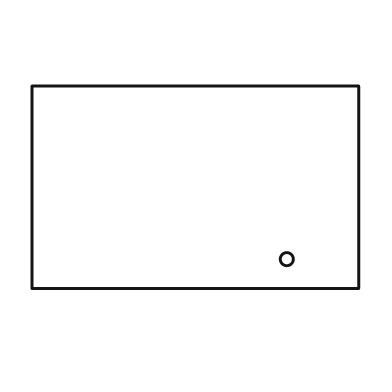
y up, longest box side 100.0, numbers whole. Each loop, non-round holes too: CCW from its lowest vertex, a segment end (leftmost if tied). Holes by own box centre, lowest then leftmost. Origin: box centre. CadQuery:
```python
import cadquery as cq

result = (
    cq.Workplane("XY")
    .moveTo(-50.0, -31.0)
    .lineTo(50.0, -31.0)
    .lineTo(50.0, 31.0)
    .lineTo(-50.0, 31.0)
    .close()
    .moveTo(28.0, -22.0)
    .circle(2.0)
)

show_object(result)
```